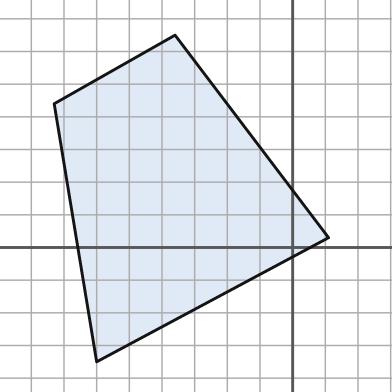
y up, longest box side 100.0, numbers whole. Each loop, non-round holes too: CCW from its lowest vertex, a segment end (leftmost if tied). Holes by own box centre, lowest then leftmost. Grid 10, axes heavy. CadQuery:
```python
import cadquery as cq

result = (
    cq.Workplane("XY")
    .moveTo(-60.0, -35.0)
    .lineTo(11.0, 3.0)
    .lineTo(-36.0, 65.0)
    .lineTo(-73.0, 44.0)
    .close()
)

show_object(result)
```